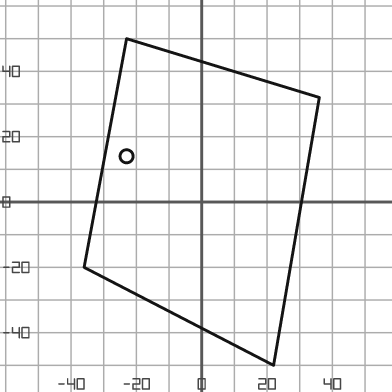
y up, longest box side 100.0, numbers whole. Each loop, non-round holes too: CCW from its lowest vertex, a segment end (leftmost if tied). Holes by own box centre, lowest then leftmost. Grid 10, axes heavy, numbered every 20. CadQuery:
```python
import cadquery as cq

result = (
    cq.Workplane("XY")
    .moveTo(22.0, -50.0)
    .lineTo(36.0, 32.0)
    .lineTo(-23.0, 50.0)
    .lineTo(-36.0, -20.0)
    .close()
    .moveTo(-23.0, 14.0)
    .circle(2.0)
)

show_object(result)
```